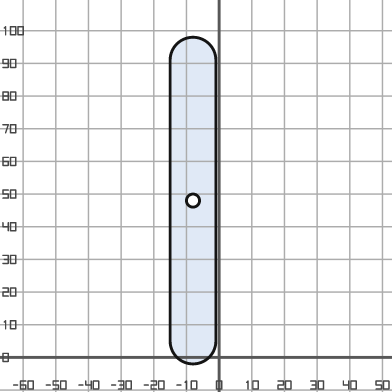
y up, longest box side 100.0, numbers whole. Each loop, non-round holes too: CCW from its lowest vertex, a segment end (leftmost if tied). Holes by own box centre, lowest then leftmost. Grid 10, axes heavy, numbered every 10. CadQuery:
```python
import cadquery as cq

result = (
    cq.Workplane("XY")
    .moveTo(-15.0, 5.0)
    .threePointArc((-8.0, -2.0), (-1.0, 5.0))
    .lineTo(-1.0, 91.0)
    .threePointArc((-8.0, 98.0), (-15.0, 91.0))
    .close()
    .moveTo(-8.0, 48.0)
    .circle(2.0)
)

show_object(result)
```